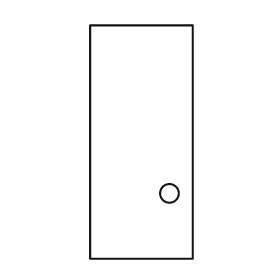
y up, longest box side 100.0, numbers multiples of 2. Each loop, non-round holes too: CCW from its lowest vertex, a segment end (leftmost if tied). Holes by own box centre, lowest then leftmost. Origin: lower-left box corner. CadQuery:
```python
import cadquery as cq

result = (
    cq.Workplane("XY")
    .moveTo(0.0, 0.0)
    .lineTo(44.0, 0.0)
    .lineTo(44.0, 100.0)
    .lineTo(0.0, 100.0)
    .close()
    .moveTo(34.0, 28.0)
    .circle(4.0)
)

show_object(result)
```